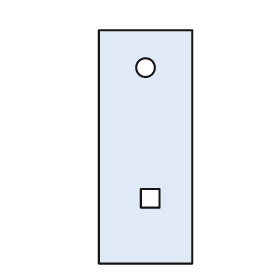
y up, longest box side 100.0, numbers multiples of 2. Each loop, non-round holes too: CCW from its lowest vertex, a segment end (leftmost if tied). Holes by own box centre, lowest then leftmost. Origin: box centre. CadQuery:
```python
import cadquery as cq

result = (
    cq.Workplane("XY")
    .moveTo(-20.0, -50.0)
    .lineTo(20.0, -50.0)
    .lineTo(20.0, 50.0)
    .lineTo(-20.0, 50.0)
    .close()
    .moveTo(-2.0, -26.0)
    .lineTo(6.0, -26.0)
    .lineTo(6.0, -18.0)
    .lineTo(-2.0, -18.0)
    .close()
    .moveTo(0.0, 34.0)
    .circle(4.0)
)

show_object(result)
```